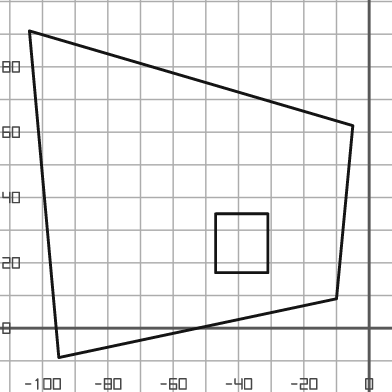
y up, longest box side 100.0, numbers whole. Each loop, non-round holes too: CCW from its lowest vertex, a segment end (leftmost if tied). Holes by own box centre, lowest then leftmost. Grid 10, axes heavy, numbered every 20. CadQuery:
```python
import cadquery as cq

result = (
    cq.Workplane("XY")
    .moveTo(-95.0, -9.0)
    .lineTo(-10.0, 9.0)
    .lineTo(-5.0, 62.0)
    .lineTo(-104.0, 91.0)
    .close()
    .moveTo(-47.0, 17.0)
    .lineTo(-31.0, 17.0)
    .lineTo(-31.0, 35.0)
    .lineTo(-47.0, 35.0)
    .close()
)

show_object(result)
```